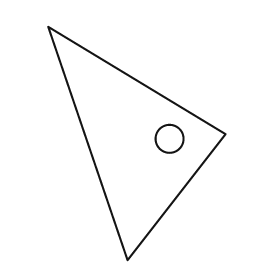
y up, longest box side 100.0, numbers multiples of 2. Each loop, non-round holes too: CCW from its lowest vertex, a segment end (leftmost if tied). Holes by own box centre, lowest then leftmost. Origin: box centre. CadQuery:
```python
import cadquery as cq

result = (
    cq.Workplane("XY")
    .moveTo(-4.0, -50.0)
    .lineTo(38.0, 4.0)
    .lineTo(-38.0, 50.0)
    .close()
    .moveTo(14.0, 2.0)
    .circle(6.0)
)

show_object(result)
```